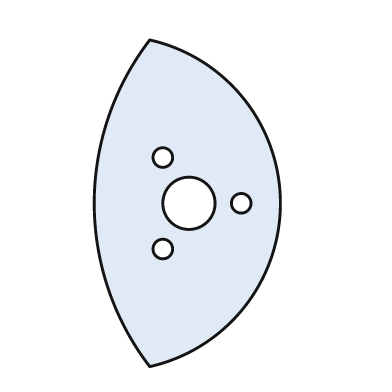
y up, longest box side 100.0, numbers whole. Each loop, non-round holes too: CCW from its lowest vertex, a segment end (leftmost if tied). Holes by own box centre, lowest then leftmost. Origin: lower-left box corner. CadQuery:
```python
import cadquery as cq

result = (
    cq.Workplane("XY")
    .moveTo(17.0, 0.0)
    .threePointArc((57.0, 50.0), (17.0, 100.0))
    .threePointArc((0.0, 50.0), (17.0, 0.0))
    .close()
    .moveTo(21.0, 36.0)
    .circle(3.0)
    .moveTo(29.0, 50.0)
    .circle(8.0)
    .moveTo(45.0, 50.0)
    .circle(3.0)
    .moveTo(21.0, 64.0)
    .circle(3.0)
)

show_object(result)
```